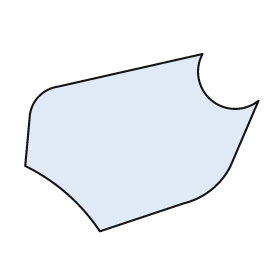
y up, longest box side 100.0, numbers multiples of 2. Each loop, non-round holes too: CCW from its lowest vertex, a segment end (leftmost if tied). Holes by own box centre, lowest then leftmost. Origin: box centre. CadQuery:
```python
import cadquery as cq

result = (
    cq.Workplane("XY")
    .moveTo(-18.0, -38.0)
    .lineTo(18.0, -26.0)
    .threePointArc((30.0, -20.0), (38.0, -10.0))
    .lineTo(50.0, 18.0)
    .threePointArc((30.0, 18.0), (26.0, 38.0))
    .lineTo(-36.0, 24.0)
    .threePointArc((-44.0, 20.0), (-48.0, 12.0))
    .lineTo(-50.0, -10.0)
    .threePointArc((-32.0, -22.0), (-18.0, -38.0))
    .close()
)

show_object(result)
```